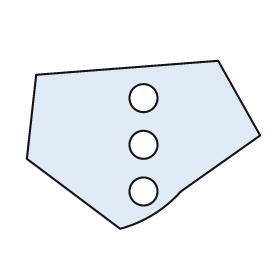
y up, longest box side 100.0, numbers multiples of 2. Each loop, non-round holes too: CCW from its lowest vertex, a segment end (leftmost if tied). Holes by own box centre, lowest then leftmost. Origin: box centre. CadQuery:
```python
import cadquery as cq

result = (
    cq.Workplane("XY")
    .moveTo(-10.0, -36.0)
    .threePointArc((4.0, -30.0), (16.0, -20.0))
    .lineTo(50.0, 4.0)
    .lineTo(32.0, 36.0)
    .lineTo(-46.0, 30.0)
    .lineTo(-50.0, -6.0)
    .close()
    .moveTo(0.0, -20.0)
    .circle(6.0)
    .moveTo(0.0, 0.0)
    .circle(6.0)
    .moveTo(0.0, 20.0)
    .circle(6.0)
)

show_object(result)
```